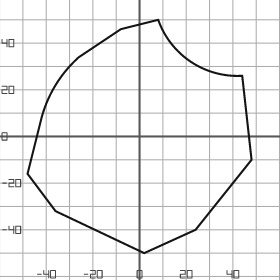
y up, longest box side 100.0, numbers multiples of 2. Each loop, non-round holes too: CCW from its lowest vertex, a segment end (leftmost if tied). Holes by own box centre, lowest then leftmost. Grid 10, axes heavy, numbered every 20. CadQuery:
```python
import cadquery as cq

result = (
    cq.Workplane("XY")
    .moveTo(2.0, -50.0)
    .lineTo(24.0, -40.0)
    .lineTo(48.0, -10.0)
    .lineTo(44.0, 26.0)
    .threePointArc((22.0, 32.0), (8.0, 50.0))
    .lineTo(-8.0, 46.0)
    .lineTo(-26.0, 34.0)
    .threePointArc((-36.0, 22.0), (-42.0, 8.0))
    .lineTo(-48.0, -16.0)
    .lineTo(-36.0, -32.0)
    .close()
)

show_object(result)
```